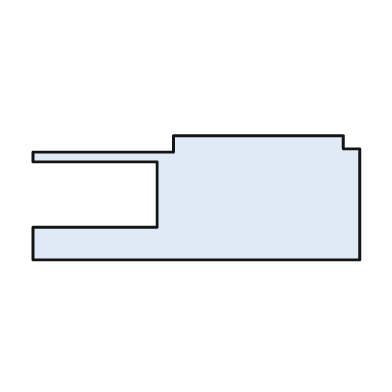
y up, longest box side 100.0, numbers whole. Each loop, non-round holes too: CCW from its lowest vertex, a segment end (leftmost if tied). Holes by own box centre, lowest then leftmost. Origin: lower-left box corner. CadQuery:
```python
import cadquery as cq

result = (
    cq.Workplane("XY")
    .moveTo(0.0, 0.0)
    .lineTo(100.0, 0.0)
    .lineTo(100.0, 34.0)
    .lineTo(95.0, 34.0)
    .lineTo(95.0, 38.0)
    .lineTo(43.0, 38.0)
    .lineTo(43.0, 33.0)
    .lineTo(0.0, 33.0)
    .lineTo(0.0, 30.0)
    .lineTo(38.0, 30.0)
    .lineTo(38.0, 10.0)
    .lineTo(0.0, 10.0)
    .close()
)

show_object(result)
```